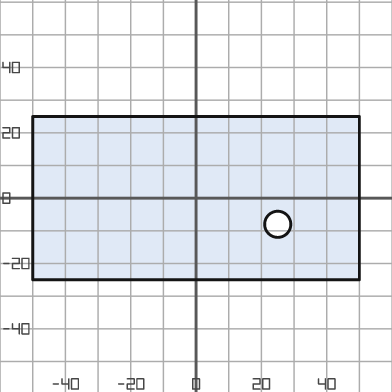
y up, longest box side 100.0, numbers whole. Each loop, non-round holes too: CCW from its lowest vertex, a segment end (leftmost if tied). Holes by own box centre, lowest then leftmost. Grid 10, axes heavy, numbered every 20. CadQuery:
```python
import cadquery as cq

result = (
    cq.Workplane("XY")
    .moveTo(-50.0, -25.0)
    .lineTo(50.0, -25.0)
    .lineTo(50.0, 25.0)
    .lineTo(-50.0, 25.0)
    .close()
    .moveTo(25.0, -8.0)
    .circle(4.0)
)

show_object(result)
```